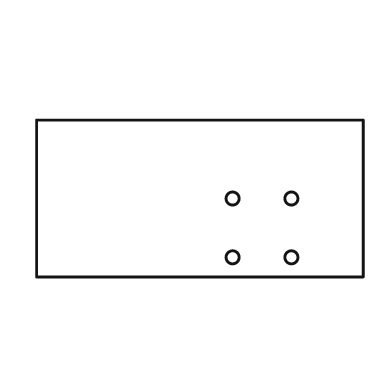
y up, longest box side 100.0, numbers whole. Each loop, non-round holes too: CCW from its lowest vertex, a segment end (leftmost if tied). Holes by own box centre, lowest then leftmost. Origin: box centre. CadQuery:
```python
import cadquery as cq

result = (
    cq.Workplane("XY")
    .moveTo(-50.0, -24.0)
    .lineTo(50.0, -24.0)
    .lineTo(50.0, 24.0)
    .lineTo(-50.0, 24.0)
    .close()
    .moveTo(10.0, -18.0)
    .circle(2.0)
    .moveTo(28.0, -18.0)
    .circle(2.0)
    .moveTo(10.0, 0.0)
    .circle(2.0)
    .moveTo(28.0, 0.0)
    .circle(2.0)
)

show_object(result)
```